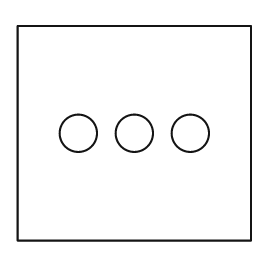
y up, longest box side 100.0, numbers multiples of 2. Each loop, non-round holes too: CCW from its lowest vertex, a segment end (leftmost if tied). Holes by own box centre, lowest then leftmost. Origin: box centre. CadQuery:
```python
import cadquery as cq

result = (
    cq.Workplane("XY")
    .moveTo(-50.0, -46.0)
    .lineTo(50.0, -46.0)
    .lineTo(50.0, 46.0)
    .lineTo(-50.0, 46.0)
    .close()
    .moveTo(-24.0, 0.0)
    .circle(8.0)
    .moveTo(0.0, 0.0)
    .circle(8.0)
    .moveTo(24.0, 0.0)
    .circle(8.0)
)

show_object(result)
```